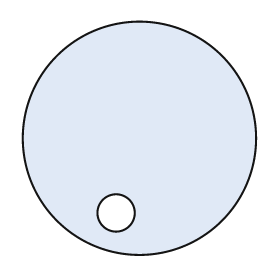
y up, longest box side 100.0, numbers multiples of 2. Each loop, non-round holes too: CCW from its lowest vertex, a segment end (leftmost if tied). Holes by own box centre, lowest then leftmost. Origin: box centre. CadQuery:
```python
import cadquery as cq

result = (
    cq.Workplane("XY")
    .moveTo(0.0, 0.0)
    .circle(50.0)
    .moveTo(-10.0, -32.0)
    .circle(8.0)
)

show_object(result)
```